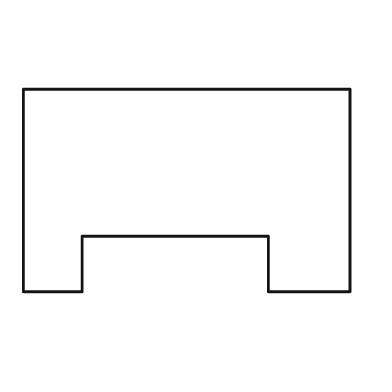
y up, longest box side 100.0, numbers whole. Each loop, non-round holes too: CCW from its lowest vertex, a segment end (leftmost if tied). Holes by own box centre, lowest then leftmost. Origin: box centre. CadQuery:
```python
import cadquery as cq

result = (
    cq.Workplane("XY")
    .moveTo(-50.0, -31.0)
    .lineTo(-32.0, -31.0)
    .lineTo(-32.0, -14.0)
    .lineTo(25.0, -14.0)
    .lineTo(25.0, -31.0)
    .lineTo(50.0, -31.0)
    .lineTo(50.0, 31.0)
    .lineTo(-50.0, 31.0)
    .close()
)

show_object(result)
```